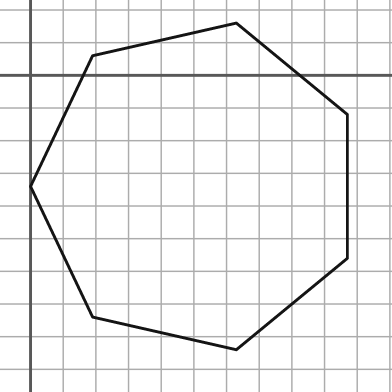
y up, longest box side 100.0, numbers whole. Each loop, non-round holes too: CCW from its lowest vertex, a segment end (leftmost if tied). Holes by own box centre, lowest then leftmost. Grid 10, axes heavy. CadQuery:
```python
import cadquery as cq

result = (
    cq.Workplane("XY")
    .moveTo(63.0, -84.0)
    .lineTo(97.0, -56.0)
    .lineTo(97.0, -12.0)
    .lineTo(63.0, 16.0)
    .lineTo(19.0, 6.0)
    .lineTo(0.0, -34.0)
    .lineTo(19.0, -74.0)
    .close()
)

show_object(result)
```